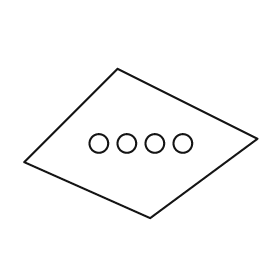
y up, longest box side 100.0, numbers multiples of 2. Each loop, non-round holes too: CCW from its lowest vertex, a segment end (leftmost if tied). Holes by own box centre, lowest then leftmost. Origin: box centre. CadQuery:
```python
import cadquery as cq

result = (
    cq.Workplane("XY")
    .moveTo(4.0, -32.0)
    .lineTo(50.0, 2.0)
    .lineTo(-10.0, 32.0)
    .lineTo(-50.0, -8.0)
    .close()
    .moveTo(-18.0, 0.0)
    .circle(4.0)
    .moveTo(-6.0, 0.0)
    .circle(4.0)
    .moveTo(6.0, 0.0)
    .circle(4.0)
    .moveTo(18.0, 0.0)
    .circle(4.0)
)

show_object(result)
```